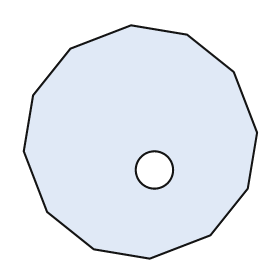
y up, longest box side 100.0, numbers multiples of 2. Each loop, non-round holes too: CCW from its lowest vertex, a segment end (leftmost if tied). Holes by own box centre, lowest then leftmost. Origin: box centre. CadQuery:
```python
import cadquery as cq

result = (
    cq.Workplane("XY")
    .moveTo(4.0, -50.0)
    .lineTo(30.0, -40.0)
    .lineTo(46.0, -20.0)
    .lineTo(50.0, 4.0)
    .lineTo(40.0, 30.0)
    .lineTo(20.0, 46.0)
    .lineTo(-4.0, 50.0)
    .lineTo(-30.0, 40.0)
    .lineTo(-46.0, 20.0)
    .lineTo(-50.0, -4.0)
    .lineTo(-40.0, -30.0)
    .lineTo(-20.0, -46.0)
    .close()
    .moveTo(6.0, -12.0)
    .circle(8.0)
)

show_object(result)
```